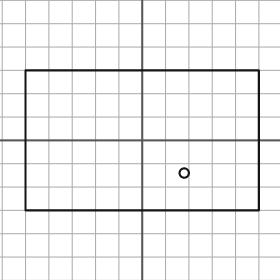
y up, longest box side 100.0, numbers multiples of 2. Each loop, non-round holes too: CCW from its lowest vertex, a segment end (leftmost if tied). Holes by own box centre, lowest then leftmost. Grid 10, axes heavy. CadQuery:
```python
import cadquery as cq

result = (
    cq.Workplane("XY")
    .moveTo(-50.0, -30.0)
    .lineTo(50.0, -30.0)
    .lineTo(50.0, 30.0)
    .lineTo(-50.0, 30.0)
    .close()
    .moveTo(18.0, -14.0)
    .circle(2.0)
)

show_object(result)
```